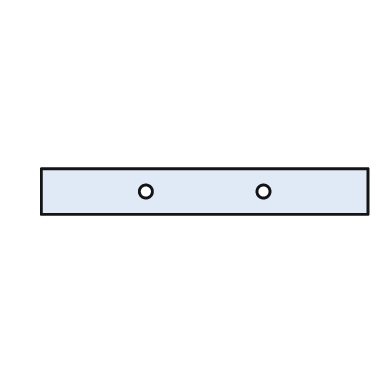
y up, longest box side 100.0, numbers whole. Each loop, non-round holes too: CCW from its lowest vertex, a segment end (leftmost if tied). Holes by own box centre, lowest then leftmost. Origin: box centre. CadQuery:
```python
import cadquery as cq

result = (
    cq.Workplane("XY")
    .moveTo(-50.0, -7.0)
    .lineTo(50.0, -7.0)
    .lineTo(50.0, 7.0)
    .lineTo(-50.0, 7.0)
    .close()
    .moveTo(-18.0, 0.0)
    .circle(2.0)
    .moveTo(18.0, 0.0)
    .circle(2.0)
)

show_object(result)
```